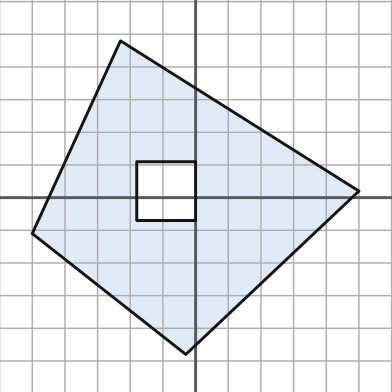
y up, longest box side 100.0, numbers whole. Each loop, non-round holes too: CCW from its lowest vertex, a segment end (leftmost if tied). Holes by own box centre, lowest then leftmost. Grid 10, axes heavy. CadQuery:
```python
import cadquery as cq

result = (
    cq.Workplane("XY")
    .moveTo(-3.0, -48.0)
    .lineTo(50.0, 2.0)
    .lineTo(-23.0, 48.0)
    .lineTo(-50.0, -11.0)
    .close()
    .moveTo(-18.0, -7.0)
    .lineTo(0.0, -7.0)
    .lineTo(0.0, 11.0)
    .lineTo(-18.0, 11.0)
    .close()
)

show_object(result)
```